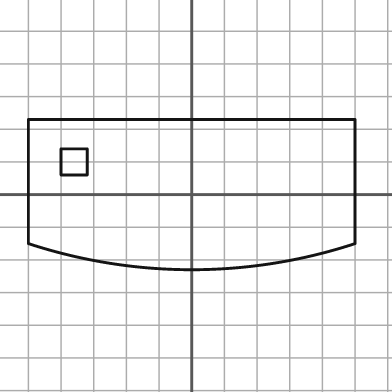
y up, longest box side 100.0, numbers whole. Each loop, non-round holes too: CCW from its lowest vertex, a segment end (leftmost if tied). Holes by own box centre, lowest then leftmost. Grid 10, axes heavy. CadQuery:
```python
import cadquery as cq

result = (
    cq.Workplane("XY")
    .moveTo(-50.0, -15.0)
    .threePointArc((0.0, -23.0), (50.0, -15.0))
    .lineTo(50.0, 23.0)
    .lineTo(-50.0, 23.0)
    .close()
    .moveTo(-40.0, 6.0)
    .lineTo(-32.0, 6.0)
    .lineTo(-32.0, 14.0)
    .lineTo(-40.0, 14.0)
    .close()
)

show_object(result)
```